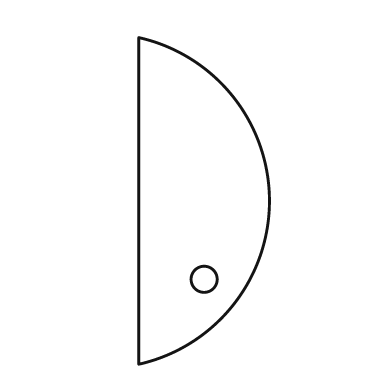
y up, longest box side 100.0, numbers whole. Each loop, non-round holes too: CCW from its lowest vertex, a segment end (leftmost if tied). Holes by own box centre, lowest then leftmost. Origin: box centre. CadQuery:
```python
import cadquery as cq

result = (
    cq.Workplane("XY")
    .moveTo(-20.0, -50.0)
    .threePointArc((20.0, 0.0), (-20.0, 50.0))
    .close()
    .moveTo(0.0, -24.0)
    .circle(4.0)
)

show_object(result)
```